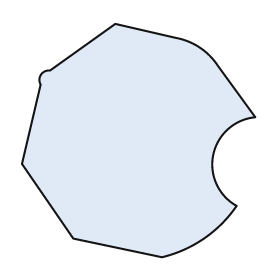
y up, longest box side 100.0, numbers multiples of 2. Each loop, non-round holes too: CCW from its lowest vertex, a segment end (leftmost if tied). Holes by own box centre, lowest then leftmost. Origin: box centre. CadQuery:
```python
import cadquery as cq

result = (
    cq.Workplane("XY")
    .moveTo(10.0, -50.0)
    .threePointArc((28.0, -42.0), (42.0, -28.0))
    .threePointArc((32.0, -6.0), (50.0, 10.0))
    .lineTo(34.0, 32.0)
    .threePointArc((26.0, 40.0), (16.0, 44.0))
    .lineTo(-10.0, 50.0)
    .lineTo(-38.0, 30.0)
    .threePointArc((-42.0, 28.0), (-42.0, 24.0))
    .lineTo(-50.0, -10.0)
    .lineTo(-28.0, -42.0)
    .close()
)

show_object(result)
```